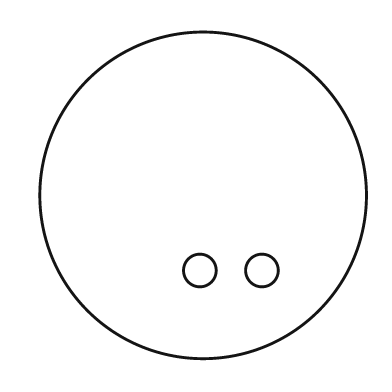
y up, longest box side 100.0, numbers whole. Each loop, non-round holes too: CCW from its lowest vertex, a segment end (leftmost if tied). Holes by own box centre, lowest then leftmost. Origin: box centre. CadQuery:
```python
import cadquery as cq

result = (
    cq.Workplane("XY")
    .moveTo(0.0, 0.0)
    .circle(50.0)
    .moveTo(-1.0, -23.0)
    .circle(5.0)
    .moveTo(18.0, -23.0)
    .circle(5.0)
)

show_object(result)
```